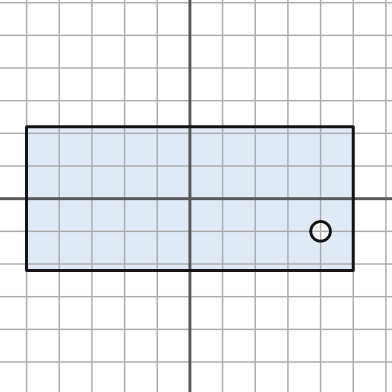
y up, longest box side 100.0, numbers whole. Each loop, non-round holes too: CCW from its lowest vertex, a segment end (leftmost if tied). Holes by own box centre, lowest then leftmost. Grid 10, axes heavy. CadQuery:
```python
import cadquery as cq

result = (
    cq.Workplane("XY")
    .moveTo(-50.0, -22.0)
    .lineTo(50.0, -22.0)
    .lineTo(50.0, 22.0)
    .lineTo(-50.0, 22.0)
    .close()
    .moveTo(40.0, -10.0)
    .circle(3.0)
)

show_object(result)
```